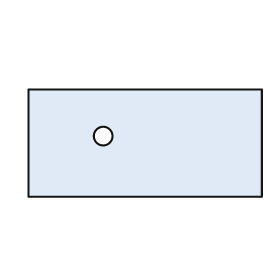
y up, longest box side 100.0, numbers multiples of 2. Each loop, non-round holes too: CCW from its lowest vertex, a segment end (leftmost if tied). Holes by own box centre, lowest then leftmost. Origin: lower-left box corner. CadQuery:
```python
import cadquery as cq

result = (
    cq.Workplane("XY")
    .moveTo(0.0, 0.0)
    .lineTo(100.0, 0.0)
    .lineTo(100.0, 46.0)
    .lineTo(0.0, 46.0)
    .close()
    .moveTo(32.0, 26.0)
    .circle(4.0)
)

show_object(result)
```